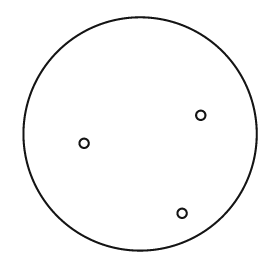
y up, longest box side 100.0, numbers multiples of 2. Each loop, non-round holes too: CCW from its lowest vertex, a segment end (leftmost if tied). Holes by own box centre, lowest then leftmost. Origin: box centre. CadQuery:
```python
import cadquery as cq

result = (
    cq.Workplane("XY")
    .moveTo(0.0, 0.0)
    .circle(50.0)
    .moveTo(18.0, -34.0)
    .circle(2.0)
    .moveTo(-24.0, -4.0)
    .circle(2.0)
    .moveTo(26.0, 8.0)
    .circle(2.0)
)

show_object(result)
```